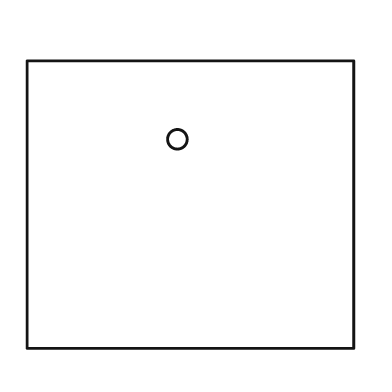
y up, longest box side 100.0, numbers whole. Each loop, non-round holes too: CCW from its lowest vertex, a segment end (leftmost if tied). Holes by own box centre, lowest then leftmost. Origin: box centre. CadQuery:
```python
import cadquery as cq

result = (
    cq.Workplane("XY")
    .moveTo(-50.0, -44.0)
    .lineTo(50.0, -44.0)
    .lineTo(50.0, 44.0)
    .lineTo(-50.0, 44.0)
    .close()
    .moveTo(-4.0, 20.0)
    .circle(3.0)
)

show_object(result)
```